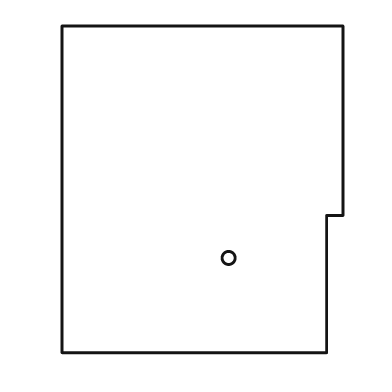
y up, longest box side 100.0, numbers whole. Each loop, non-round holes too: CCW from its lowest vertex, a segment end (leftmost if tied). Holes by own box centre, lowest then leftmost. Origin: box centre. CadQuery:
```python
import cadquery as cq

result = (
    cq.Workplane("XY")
    .moveTo(-43.0, -50.0)
    .lineTo(38.0, -50.0)
    .lineTo(38.0, -8.0)
    .lineTo(43.0, -8.0)
    .lineTo(43.0, 50.0)
    .lineTo(-43.0, 50.0)
    .close()
    .moveTo(8.0, -21.0)
    .circle(2.0)
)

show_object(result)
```